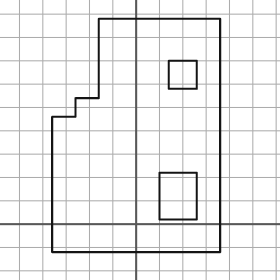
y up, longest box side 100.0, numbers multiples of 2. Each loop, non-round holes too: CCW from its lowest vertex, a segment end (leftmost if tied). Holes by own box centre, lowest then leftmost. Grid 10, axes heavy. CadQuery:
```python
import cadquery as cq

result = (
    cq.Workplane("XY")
    .moveTo(-36.0, -12.0)
    .lineTo(36.0, -12.0)
    .lineTo(36.0, 88.0)
    .lineTo(-16.0, 88.0)
    .lineTo(-16.0, 54.0)
    .lineTo(-26.0, 54.0)
    .lineTo(-26.0, 46.0)
    .lineTo(-36.0, 46.0)
    .close()
    .moveTo(10.0, 2.0)
    .lineTo(26.0, 2.0)
    .lineTo(26.0, 22.0)
    .lineTo(10.0, 22.0)
    .close()
    .moveTo(14.0, 58.0)
    .lineTo(26.0, 58.0)
    .lineTo(26.0, 70.0)
    .lineTo(14.0, 70.0)
    .close()
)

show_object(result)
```